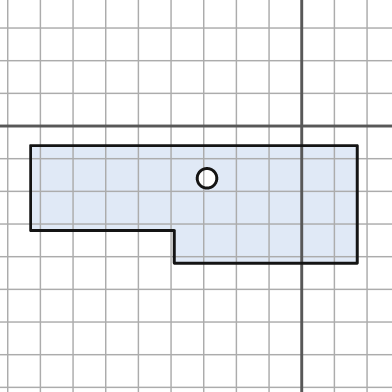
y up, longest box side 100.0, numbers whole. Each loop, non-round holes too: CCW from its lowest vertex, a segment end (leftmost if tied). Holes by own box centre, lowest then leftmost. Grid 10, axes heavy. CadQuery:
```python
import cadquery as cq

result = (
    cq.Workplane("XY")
    .moveTo(-39.0, -42.0)
    .lineTo(17.0, -42.0)
    .lineTo(17.0, -6.0)
    .lineTo(-83.0, -6.0)
    .lineTo(-83.0, -32.0)
    .lineTo(-39.0, -32.0)
    .close()
    .moveTo(-29.0, -16.0)
    .circle(3.0)
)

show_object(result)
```